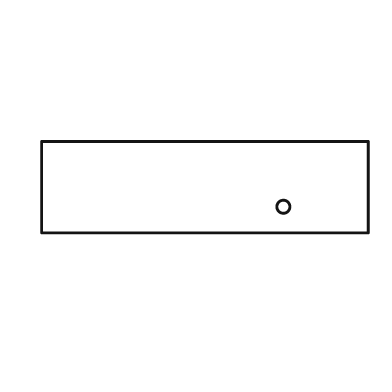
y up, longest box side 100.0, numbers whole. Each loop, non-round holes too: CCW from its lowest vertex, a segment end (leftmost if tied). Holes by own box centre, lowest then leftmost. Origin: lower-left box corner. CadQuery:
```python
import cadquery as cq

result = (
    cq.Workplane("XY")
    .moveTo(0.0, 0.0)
    .lineTo(100.0, 0.0)
    .lineTo(100.0, 28.0)
    .lineTo(0.0, 28.0)
    .close()
    .moveTo(74.0, 8.0)
    .circle(2.0)
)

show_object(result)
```